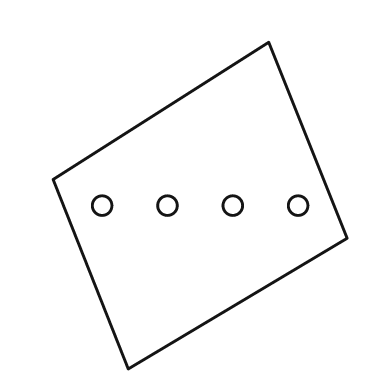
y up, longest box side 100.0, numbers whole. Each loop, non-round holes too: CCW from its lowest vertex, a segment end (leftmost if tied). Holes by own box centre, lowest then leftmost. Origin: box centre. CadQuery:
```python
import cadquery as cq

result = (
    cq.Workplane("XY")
    .moveTo(-22.0, -50.0)
    .lineTo(45.0, -10.0)
    .lineTo(21.0, 50.0)
    .lineTo(-45.0, 8.0)
    .close()
    .moveTo(-30.0, 0.0)
    .circle(3.0)
    .moveTo(-10.0, 0.0)
    .circle(3.0)
    .moveTo(10.0, 0.0)
    .circle(3.0)
    .moveTo(30.0, 0.0)
    .circle(3.0)
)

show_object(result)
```